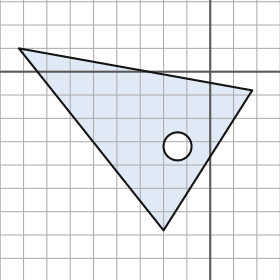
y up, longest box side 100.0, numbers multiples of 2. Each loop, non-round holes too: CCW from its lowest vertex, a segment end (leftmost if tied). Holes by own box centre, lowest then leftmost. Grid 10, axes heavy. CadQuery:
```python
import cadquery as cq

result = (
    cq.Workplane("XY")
    .moveTo(-20.0, -68.0)
    .lineTo(18.0, -8.0)
    .lineTo(-82.0, 10.0)
    .close()
    .moveTo(-14.0, -32.0)
    .circle(6.0)
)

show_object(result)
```